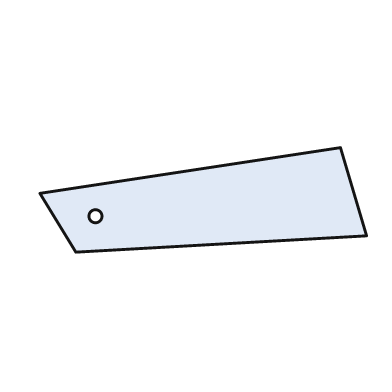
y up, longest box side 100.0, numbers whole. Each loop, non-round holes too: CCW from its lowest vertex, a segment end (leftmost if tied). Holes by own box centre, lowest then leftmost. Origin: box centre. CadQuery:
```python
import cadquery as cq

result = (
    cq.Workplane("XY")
    .moveTo(-39.0, -16.0)
    .lineTo(50.0, -11.0)
    .lineTo(42.0, 16.0)
    .lineTo(-50.0, 2.0)
    .close()
    .moveTo(-33.0, -5.0)
    .circle(2.0)
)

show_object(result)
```